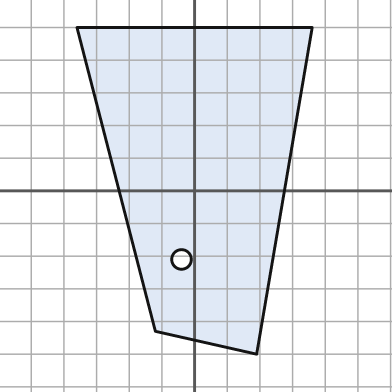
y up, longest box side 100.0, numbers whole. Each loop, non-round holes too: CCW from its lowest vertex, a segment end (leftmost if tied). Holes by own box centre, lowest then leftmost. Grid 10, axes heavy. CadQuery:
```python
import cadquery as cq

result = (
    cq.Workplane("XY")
    .moveTo(19.0, -50.0)
    .lineTo(36.0, 50.0)
    .lineTo(-36.0, 50.0)
    .lineTo(-12.0, -43.0)
    .close()
    .moveTo(-4.0, -21.0)
    .circle(3.0)
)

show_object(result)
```